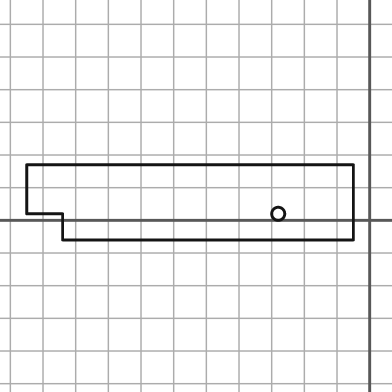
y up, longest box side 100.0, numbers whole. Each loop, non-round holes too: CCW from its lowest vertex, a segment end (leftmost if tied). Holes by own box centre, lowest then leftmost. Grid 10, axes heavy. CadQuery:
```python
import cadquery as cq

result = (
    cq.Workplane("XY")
    .moveTo(-94.0, -6.0)
    .lineTo(-5.0, -6.0)
    .lineTo(-5.0, 17.0)
    .lineTo(-105.0, 17.0)
    .lineTo(-105.0, 2.0)
    .lineTo(-94.0, 2.0)
    .close()
    .moveTo(-28.0, 2.0)
    .circle(2.0)
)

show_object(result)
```